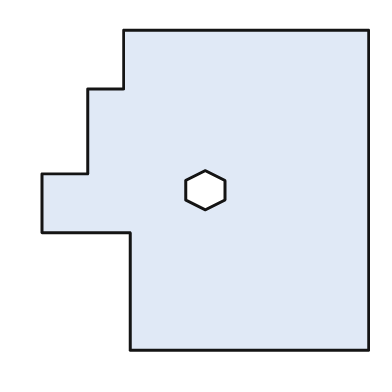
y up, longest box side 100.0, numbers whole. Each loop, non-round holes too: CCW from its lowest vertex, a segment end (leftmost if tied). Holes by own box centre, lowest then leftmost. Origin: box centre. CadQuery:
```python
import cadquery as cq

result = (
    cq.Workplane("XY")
    .moveTo(-23.0, -49.0)
    .lineTo(50.0, -49.0)
    .lineTo(50.0, 49.0)
    .lineTo(-25.0, 49.0)
    .lineTo(-25.0, 31.0)
    .lineTo(-36.0, 31.0)
    .lineTo(-36.0, 5.0)
    .lineTo(-50.0, 5.0)
    .lineTo(-50.0, -13.0)
    .lineTo(-23.0, -13.0)
    .close()
    .moveTo(0.0, -6.0)
    .lineTo(6.0, -3.0)
    .lineTo(6.0, 3.0)
    .lineTo(0.0, 6.0)
    .lineTo(-6.0, 3.0)
    .lineTo(-6.0, -3.0)
    .close()
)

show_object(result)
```